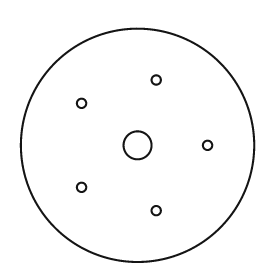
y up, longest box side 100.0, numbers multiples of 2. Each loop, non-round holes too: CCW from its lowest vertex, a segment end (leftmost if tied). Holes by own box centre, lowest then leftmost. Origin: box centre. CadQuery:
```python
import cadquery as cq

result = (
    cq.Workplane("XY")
    .moveTo(0.0, 0.0)
    .circle(50.0)
    .moveTo(8.0, -28.0)
    .circle(2.0)
    .moveTo(-24.0, -18.0)
    .circle(2.0)
    .moveTo(0.0, 0.0)
    .circle(6.0)
    .moveTo(30.0, 0.0)
    .circle(2.0)
    .moveTo(-24.0, 18.0)
    .circle(2.0)
    .moveTo(8.0, 28.0)
    .circle(2.0)
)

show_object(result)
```